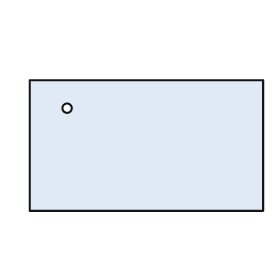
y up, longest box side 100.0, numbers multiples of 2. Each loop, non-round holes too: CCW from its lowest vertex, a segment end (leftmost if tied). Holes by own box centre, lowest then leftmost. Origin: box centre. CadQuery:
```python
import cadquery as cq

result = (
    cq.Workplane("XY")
    .moveTo(-50.0, -28.0)
    .lineTo(50.0, -28.0)
    .lineTo(50.0, 28.0)
    .lineTo(-50.0, 28.0)
    .close()
    .moveTo(-34.0, 16.0)
    .circle(2.0)
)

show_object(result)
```